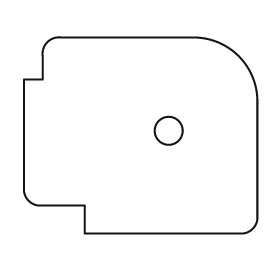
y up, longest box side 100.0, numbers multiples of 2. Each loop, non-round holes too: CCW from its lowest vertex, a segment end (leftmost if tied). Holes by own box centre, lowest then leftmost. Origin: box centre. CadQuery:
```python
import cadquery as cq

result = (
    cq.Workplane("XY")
    .moveTo(-24.0, -42.0)
    .lineTo(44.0, -42.0)
    .threePointArc((48.0, -40.0), (50.0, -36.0))
    .lineTo(50.0, 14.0)
    .threePointArc((42.0, 34.0), (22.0, 42.0))
    .lineTo(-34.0, 42.0)
    .threePointArc((-40.0, 40.0), (-42.0, 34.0))
    .lineTo(-42.0, 24.0)
    .lineTo(-50.0, 24.0)
    .lineTo(-50.0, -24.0)
    .threePointArc((-48.0, -28.0), (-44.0, -30.0))
    .lineTo(-24.0, -30.0)
    .close()
    .moveTo(12.0, 2.0)
    .circle(6.0)
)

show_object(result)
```